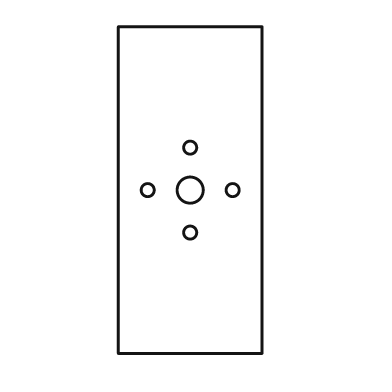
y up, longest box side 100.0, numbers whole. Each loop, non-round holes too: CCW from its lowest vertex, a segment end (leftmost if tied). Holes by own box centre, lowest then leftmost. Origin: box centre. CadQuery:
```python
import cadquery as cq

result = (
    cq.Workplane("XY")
    .moveTo(-22.0, -50.0)
    .lineTo(22.0, -50.0)
    .lineTo(22.0, 50.0)
    .lineTo(-22.0, 50.0)
    .close()
    .moveTo(0.0, -13.0)
    .circle(2.0)
    .moveTo(-13.0, 0.0)
    .circle(2.0)
    .moveTo(0.0, 0.0)
    .circle(4.0)
    .moveTo(13.0, 0.0)
    .circle(2.0)
    .moveTo(0.0, 13.0)
    .circle(2.0)
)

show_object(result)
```